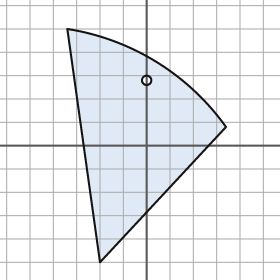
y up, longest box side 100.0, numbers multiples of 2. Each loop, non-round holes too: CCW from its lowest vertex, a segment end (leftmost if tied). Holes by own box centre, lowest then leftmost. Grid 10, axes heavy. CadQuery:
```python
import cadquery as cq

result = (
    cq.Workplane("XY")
    .moveTo(-20.0, -50.0)
    .lineTo(34.0, 8.0)
    .threePointArc((4.0, 36.0), (-34.0, 50.0))
    .close()
    .moveTo(0.0, 28.0)
    .circle(2.0)
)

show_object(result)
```